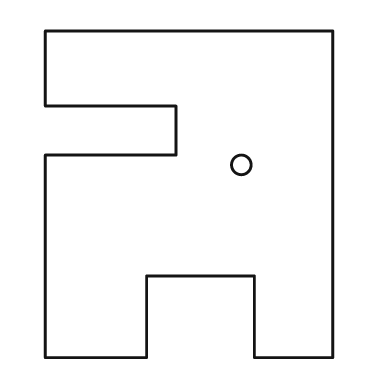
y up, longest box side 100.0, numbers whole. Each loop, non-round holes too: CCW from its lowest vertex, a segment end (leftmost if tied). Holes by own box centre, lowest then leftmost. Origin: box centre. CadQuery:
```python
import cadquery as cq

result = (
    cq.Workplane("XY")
    .moveTo(-44.0, -50.0)
    .lineTo(-13.0, -50.0)
    .lineTo(-13.0, -25.0)
    .lineTo(20.0, -25.0)
    .lineTo(20.0, -50.0)
    .lineTo(44.0, -50.0)
    .lineTo(44.0, 50.0)
    .lineTo(-44.0, 50.0)
    .lineTo(-44.0, 27.0)
    .lineTo(-4.0, 27.0)
    .lineTo(-4.0, 12.0)
    .lineTo(-44.0, 12.0)
    .close()
    .moveTo(16.0, 9.0)
    .circle(3.0)
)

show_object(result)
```